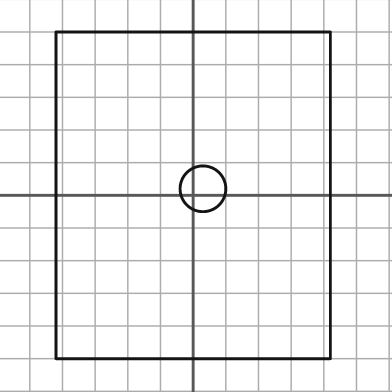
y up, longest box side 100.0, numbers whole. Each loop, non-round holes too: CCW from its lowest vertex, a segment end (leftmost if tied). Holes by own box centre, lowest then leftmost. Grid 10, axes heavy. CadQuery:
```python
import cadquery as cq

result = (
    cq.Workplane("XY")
    .moveTo(-42.0, -50.0)
    .lineTo(42.0, -50.0)
    .lineTo(42.0, 50.0)
    .lineTo(-42.0, 50.0)
    .close()
    .moveTo(3.0, 2.0)
    .circle(7.0)
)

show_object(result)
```